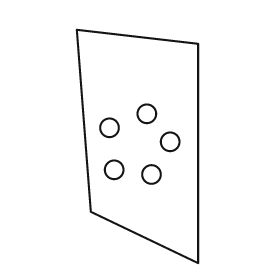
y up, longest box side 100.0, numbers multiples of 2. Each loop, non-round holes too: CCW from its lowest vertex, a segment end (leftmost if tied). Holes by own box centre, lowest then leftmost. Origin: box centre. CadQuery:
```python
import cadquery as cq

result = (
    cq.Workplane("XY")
    .moveTo(26.0, -50.0)
    .lineTo(26.0, 44.0)
    .lineTo(-26.0, 50.0)
    .lineTo(-20.0, -28.0)
    .close()
    .moveTo(6.0, -12.0)
    .circle(4.0)
    .moveTo(-10.0, -10.0)
    .circle(4.0)
    .moveTo(14.0, 2.0)
    .circle(4.0)
    .moveTo(-12.0, 8.0)
    .circle(4.0)
    .moveTo(4.0, 14.0)
    .circle(4.0)
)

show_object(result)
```